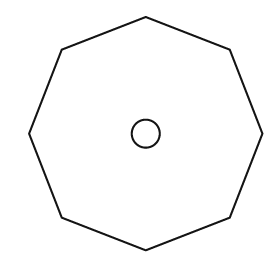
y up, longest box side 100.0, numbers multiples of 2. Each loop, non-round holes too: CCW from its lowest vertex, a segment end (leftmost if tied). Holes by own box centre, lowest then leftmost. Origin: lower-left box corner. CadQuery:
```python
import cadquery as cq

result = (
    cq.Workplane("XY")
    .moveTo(50.0, 0.0)
    .lineTo(86.0, 14.0)
    .lineTo(100.0, 50.0)
    .lineTo(86.0, 86.0)
    .lineTo(50.0, 100.0)
    .lineTo(14.0, 86.0)
    .lineTo(0.0, 50.0)
    .lineTo(14.0, 14.0)
    .close()
    .moveTo(50.0, 50.0)
    .circle(6.0)
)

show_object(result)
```